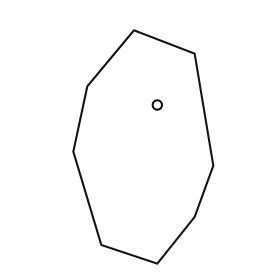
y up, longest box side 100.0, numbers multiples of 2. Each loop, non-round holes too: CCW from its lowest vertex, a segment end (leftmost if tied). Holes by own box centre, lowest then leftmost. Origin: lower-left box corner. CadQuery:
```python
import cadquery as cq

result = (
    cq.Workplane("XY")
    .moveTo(36.0, 0.0)
    .lineTo(52.0, 20.0)
    .lineTo(60.0, 42.0)
    .lineTo(52.0, 90.0)
    .lineTo(26.0, 100.0)
    .lineTo(6.0, 76.0)
    .lineTo(0.0, 48.0)
    .lineTo(12.0, 8.0)
    .close()
    .moveTo(36.0, 68.0)
    .circle(2.0)
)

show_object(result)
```